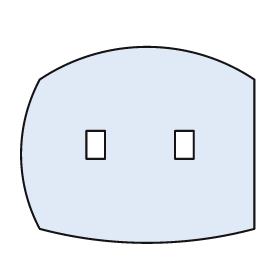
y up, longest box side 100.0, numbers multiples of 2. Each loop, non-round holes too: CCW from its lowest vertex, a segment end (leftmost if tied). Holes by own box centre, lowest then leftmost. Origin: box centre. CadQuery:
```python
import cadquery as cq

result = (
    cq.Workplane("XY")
    .moveTo(-42.0, -36.0)
    .threePointArc((4.0, -42.0), (50.0, -36.0))
    .lineTo(50.0, 28.0)
    .threePointArc((4.0, 42.0), (-42.0, 28.0))
    .threePointArc((-50.0, -4.0), (-42.0, -36.0))
    .close()
    .moveTo(-22.0, -6.0)
    .lineTo(-14.0, -6.0)
    .lineTo(-14.0, 6.0)
    .lineTo(-22.0, 6.0)
    .close()
    .moveTo(16.0, -6.0)
    .lineTo(24.0, -6.0)
    .lineTo(24.0, 6.0)
    .lineTo(16.0, 6.0)
    .close()
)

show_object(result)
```